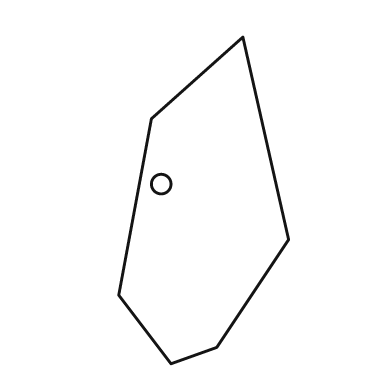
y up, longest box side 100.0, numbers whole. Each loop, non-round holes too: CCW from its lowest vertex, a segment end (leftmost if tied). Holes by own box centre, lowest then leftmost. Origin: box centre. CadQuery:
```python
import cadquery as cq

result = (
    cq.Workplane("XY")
    .moveTo(-10.0, -50.0)
    .lineTo(4.0, -45.0)
    .lineTo(26.0, -12.0)
    .lineTo(12.0, 50.0)
    .lineTo(-16.0, 25.0)
    .lineTo(-26.0, -29.0)
    .close()
    .moveTo(-13.0, 5.0)
    .circle(3.0)
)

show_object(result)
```